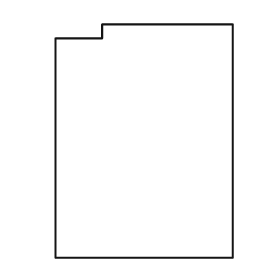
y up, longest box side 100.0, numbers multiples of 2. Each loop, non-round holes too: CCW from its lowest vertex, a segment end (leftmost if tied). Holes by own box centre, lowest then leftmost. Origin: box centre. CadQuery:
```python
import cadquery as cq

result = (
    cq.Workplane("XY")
    .moveTo(-38.0, -50.0)
    .lineTo(38.0, -50.0)
    .lineTo(38.0, 50.0)
    .lineTo(-18.0, 50.0)
    .lineTo(-18.0, 44.0)
    .lineTo(-38.0, 44.0)
    .close()
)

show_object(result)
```